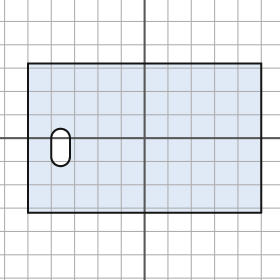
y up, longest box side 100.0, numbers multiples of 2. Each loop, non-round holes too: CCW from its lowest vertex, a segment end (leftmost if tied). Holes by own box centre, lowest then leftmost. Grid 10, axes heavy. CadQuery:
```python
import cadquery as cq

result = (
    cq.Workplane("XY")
    .moveTo(-50.0, -32.0)
    .lineTo(50.0, -32.0)
    .lineTo(50.0, 32.0)
    .lineTo(-50.0, 32.0)
    .close()
    .moveTo(-40.0, -8.0)
    .threePointArc((-36.0, -12.0), (-32.0, -8.0))
    .lineTo(-32.0, 0.0)
    .threePointArc((-36.0, 4.0), (-40.0, 0.0))
    .close()
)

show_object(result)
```